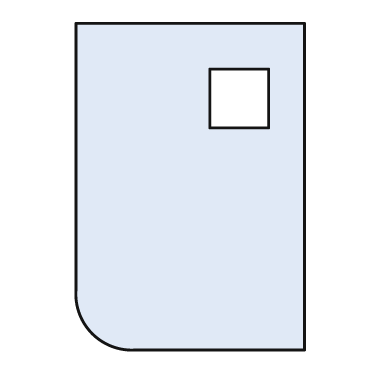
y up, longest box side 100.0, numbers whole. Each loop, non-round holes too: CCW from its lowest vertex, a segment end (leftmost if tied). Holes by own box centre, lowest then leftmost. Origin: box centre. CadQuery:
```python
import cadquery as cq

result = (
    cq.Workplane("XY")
    .moveTo(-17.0, -50.0)
    .lineTo(35.0, -50.0)
    .lineTo(35.0, 50.0)
    .lineTo(-35.0, 50.0)
    .lineTo(-35.0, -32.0)
    .threePointArc((-30.0, -45.0), (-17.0, -50.0))
    .close()
    .moveTo(6.0, 18.0)
    .lineTo(24.0, 18.0)
    .lineTo(24.0, 36.0)
    .lineTo(6.0, 36.0)
    .close()
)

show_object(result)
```